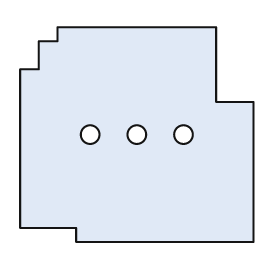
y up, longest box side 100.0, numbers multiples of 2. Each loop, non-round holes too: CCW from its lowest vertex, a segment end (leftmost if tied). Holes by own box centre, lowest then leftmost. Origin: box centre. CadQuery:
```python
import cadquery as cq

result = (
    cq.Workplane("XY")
    .moveTo(-26.0, -46.0)
    .lineTo(50.0, -46.0)
    .lineTo(50.0, 14.0)
    .lineTo(34.0, 14.0)
    .lineTo(34.0, 46.0)
    .lineTo(-34.0, 46.0)
    .lineTo(-34.0, 40.0)
    .lineTo(-42.0, 40.0)
    .lineTo(-42.0, 28.0)
    .lineTo(-50.0, 28.0)
    .lineTo(-50.0, -40.0)
    .lineTo(-26.0, -40.0)
    .close()
    .moveTo(-20.0, 0.0)
    .circle(4.0)
    .moveTo(0.0, 0.0)
    .circle(4.0)
    .moveTo(20.0, 0.0)
    .circle(4.0)
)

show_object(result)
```